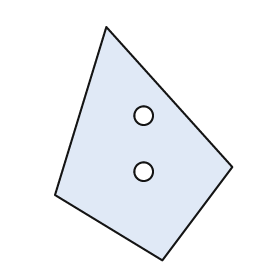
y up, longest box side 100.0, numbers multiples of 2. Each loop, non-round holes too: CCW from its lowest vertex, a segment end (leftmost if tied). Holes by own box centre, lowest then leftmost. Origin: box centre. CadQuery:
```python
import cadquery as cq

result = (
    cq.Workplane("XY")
    .moveTo(8.0, -50.0)
    .lineTo(38.0, -10.0)
    .lineTo(-16.0, 50.0)
    .lineTo(-38.0, -22.0)
    .close()
    .moveTo(0.0, -12.0)
    .circle(4.0)
    .moveTo(0.0, 12.0)
    .circle(4.0)
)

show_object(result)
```